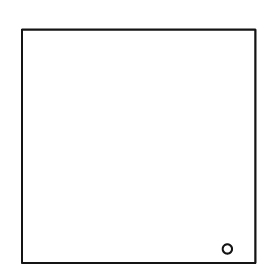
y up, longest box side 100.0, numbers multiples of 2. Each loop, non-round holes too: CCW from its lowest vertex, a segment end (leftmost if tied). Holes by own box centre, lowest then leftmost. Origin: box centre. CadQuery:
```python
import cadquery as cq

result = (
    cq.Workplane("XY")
    .moveTo(-50.0, -50.0)
    .lineTo(50.0, -50.0)
    .lineTo(50.0, 50.0)
    .lineTo(-50.0, 50.0)
    .close()
    .moveTo(38.0, -44.0)
    .circle(2.0)
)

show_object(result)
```